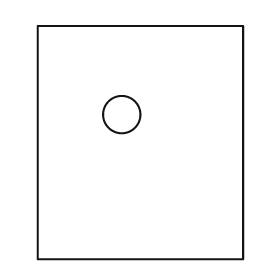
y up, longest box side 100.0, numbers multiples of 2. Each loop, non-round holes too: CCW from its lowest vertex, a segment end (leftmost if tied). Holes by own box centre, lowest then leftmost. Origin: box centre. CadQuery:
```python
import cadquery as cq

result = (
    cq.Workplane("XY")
    .moveTo(-44.0, -50.0)
    .lineTo(44.0, -50.0)
    .lineTo(44.0, 50.0)
    .lineTo(-44.0, 50.0)
    .close()
    .moveTo(-8.0, 12.0)
    .circle(8.0)
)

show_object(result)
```